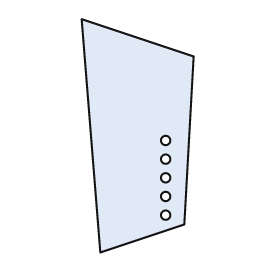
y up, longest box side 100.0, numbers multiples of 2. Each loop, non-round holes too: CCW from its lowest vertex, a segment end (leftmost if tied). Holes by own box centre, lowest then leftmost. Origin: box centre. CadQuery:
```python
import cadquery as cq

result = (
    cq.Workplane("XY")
    .moveTo(-16.0, -50.0)
    .lineTo(20.0, -38.0)
    .lineTo(24.0, 34.0)
    .lineTo(-24.0, 50.0)
    .close()
    .moveTo(12.0, -34.0)
    .circle(2.0)
    .moveTo(12.0, -26.0)
    .circle(2.0)
    .moveTo(12.0, -18.0)
    .circle(2.0)
    .moveTo(12.0, -10.0)
    .circle(2.0)
    .moveTo(12.0, -2.0)
    .circle(2.0)
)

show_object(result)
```